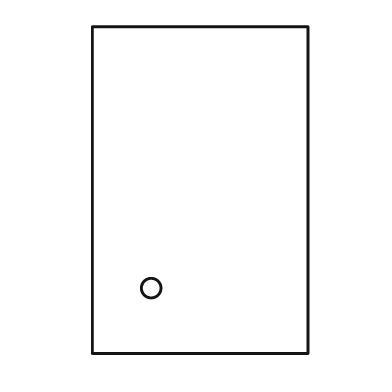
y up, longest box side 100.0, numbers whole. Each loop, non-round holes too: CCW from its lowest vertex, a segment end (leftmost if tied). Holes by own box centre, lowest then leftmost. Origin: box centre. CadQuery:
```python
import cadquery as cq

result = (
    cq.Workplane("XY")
    .moveTo(-33.0, -50.0)
    .lineTo(33.0, -50.0)
    .lineTo(33.0, 50.0)
    .lineTo(-33.0, 50.0)
    .close()
    .moveTo(-15.0, -30.0)
    .circle(3.0)
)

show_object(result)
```